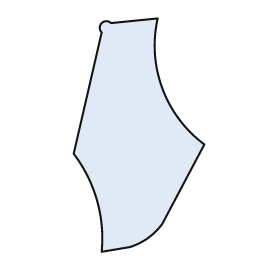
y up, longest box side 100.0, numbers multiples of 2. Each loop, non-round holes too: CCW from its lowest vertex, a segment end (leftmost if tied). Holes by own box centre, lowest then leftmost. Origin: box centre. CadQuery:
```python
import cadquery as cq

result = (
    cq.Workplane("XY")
    .moveTo(-16.0, -50.0)
    .lineTo(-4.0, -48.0)
    .threePointArc((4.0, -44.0), (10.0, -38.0))
    .lineTo(28.0, -4.0)
    .threePointArc((10.0, 20.0), (8.0, 50.0))
    .lineTo(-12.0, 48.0)
    .threePointArc((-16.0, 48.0), (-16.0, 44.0))
    .lineTo(-28.0, -8.0)
    .threePointArc((-18.0, -28.0), (-16.0, -50.0))
    .close()
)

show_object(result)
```